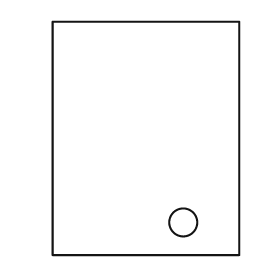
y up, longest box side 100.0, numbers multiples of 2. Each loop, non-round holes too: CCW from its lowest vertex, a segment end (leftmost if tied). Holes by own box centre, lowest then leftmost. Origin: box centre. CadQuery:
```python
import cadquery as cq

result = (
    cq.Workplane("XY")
    .moveTo(-40.0, -50.0)
    .lineTo(40.0, -50.0)
    .lineTo(40.0, 50.0)
    .lineTo(-40.0, 50.0)
    .close()
    .moveTo(16.0, -36.0)
    .circle(6.0)
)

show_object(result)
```